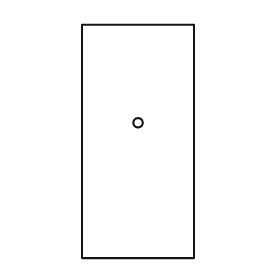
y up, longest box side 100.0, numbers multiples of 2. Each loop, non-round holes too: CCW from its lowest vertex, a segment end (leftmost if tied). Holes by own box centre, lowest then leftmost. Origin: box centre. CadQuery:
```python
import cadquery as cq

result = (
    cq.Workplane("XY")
    .moveTo(-24.0, -50.0)
    .lineTo(24.0, -50.0)
    .lineTo(24.0, 50.0)
    .lineTo(-24.0, 50.0)
    .close()
    .moveTo(0.0, 8.0)
    .circle(2.0)
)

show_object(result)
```